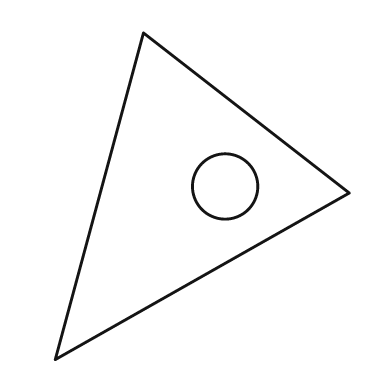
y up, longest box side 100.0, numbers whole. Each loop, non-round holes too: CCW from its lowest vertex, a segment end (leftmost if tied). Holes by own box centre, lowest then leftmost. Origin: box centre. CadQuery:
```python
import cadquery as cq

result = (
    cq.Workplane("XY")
    .moveTo(-45.0, -50.0)
    .lineTo(45.0, 1.0)
    .lineTo(-18.0, 50.0)
    .close()
    .moveTo(7.0, 3.0)
    .circle(10.0)
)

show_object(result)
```